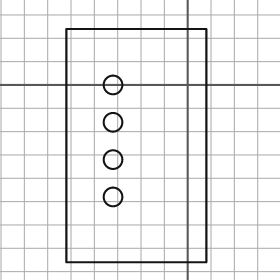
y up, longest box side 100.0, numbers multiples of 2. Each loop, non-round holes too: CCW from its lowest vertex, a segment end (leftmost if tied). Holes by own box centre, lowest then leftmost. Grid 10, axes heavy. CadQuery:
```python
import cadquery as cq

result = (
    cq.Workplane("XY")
    .moveTo(-52.0, -76.0)
    .lineTo(8.0, -76.0)
    .lineTo(8.0, 24.0)
    .lineTo(-52.0, 24.0)
    .close()
    .moveTo(-32.0, -48.0)
    .circle(4.0)
    .moveTo(-32.0, -32.0)
    .circle(4.0)
    .moveTo(-32.0, -16.0)
    .circle(4.0)
    .moveTo(-32.0, 0.0)
    .circle(4.0)
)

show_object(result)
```